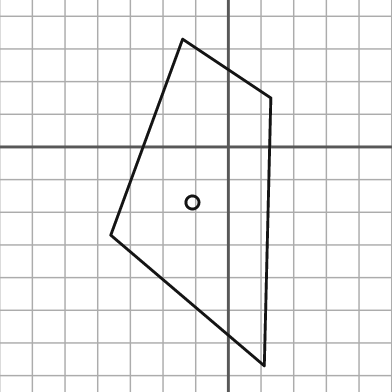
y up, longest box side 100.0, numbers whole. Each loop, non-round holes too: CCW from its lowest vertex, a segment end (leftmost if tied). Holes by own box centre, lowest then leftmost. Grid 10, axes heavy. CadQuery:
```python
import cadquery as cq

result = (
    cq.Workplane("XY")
    .moveTo(11.0, -67.0)
    .lineTo(13.0, 15.0)
    .lineTo(-14.0, 33.0)
    .lineTo(-36.0, -27.0)
    .close()
    .moveTo(-11.0, -17.0)
    .circle(2.0)
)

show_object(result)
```